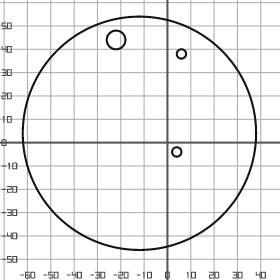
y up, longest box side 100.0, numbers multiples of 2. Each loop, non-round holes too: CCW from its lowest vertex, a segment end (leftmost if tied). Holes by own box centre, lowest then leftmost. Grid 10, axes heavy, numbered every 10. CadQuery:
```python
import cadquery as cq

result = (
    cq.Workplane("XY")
    .moveTo(-12.0, 4.0)
    .circle(50.0)
    .moveTo(4.0, -4.0)
    .circle(2.0)
    .moveTo(6.0, 38.0)
    .circle(2.0)
    .moveTo(-22.0, 44.0)
    .circle(4.0)
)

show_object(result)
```